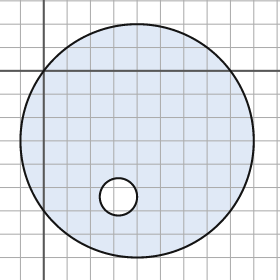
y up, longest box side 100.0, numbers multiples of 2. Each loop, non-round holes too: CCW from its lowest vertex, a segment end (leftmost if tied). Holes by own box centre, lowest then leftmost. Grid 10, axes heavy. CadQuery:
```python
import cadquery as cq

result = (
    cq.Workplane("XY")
    .moveTo(40.0, -30.0)
    .circle(50.0)
    .moveTo(32.0, -54.0)
    .circle(8.0)
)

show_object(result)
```